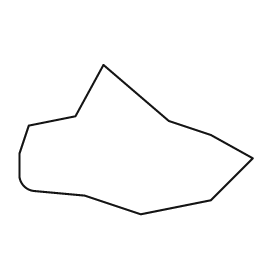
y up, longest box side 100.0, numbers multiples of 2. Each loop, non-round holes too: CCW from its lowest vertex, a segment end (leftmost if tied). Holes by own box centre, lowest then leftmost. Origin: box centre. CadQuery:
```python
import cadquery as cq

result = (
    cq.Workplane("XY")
    .moveTo(2.0, -32.0)
    .lineTo(32.0, -26.0)
    .lineTo(50.0, -8.0)
    .lineTo(32.0, 2.0)
    .lineTo(14.0, 8.0)
    .lineTo(-14.0, 32.0)
    .lineTo(-26.0, 10.0)
    .lineTo(-46.0, 6.0)
    .lineTo(-50.0, -6.0)
    .lineTo(-50.0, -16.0)
    .threePointArc((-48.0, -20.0), (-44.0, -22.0))
    .lineTo(-22.0, -24.0)
    .close()
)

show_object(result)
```